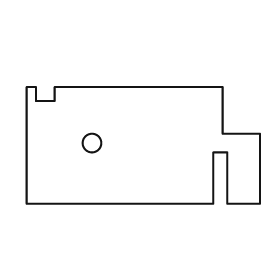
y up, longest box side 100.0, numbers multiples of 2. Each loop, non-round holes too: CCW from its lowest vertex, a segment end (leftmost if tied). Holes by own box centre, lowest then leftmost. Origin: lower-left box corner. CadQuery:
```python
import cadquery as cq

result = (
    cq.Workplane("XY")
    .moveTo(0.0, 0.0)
    .lineTo(80.0, 0.0)
    .lineTo(80.0, 22.0)
    .lineTo(86.0, 22.0)
    .lineTo(86.0, 0.0)
    .lineTo(100.0, 0.0)
    .lineTo(100.0, 30.0)
    .lineTo(84.0, 30.0)
    .lineTo(84.0, 50.0)
    .lineTo(12.0, 50.0)
    .lineTo(12.0, 44.0)
    .lineTo(4.0, 44.0)
    .lineTo(4.0, 50.0)
    .lineTo(0.0, 50.0)
    .close()
    .moveTo(28.0, 26.0)
    .circle(4.0)
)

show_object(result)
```